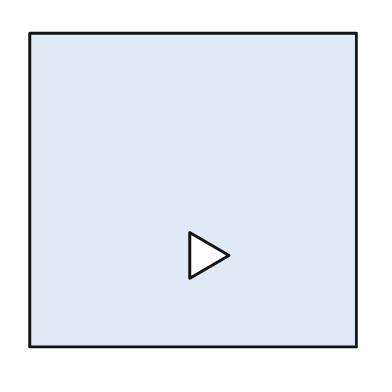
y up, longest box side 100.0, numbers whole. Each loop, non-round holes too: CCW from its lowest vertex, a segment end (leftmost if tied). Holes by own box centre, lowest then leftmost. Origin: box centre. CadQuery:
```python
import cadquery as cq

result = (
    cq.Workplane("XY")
    .moveTo(-50.0, -48.0)
    .lineTo(50.0, -48.0)
    .lineTo(50.0, 48.0)
    .lineTo(-50.0, 48.0)
    .close()
    .moveTo(-1.0, -27.0)
    .lineTo(11.0, -20.0)
    .lineTo(-1.0, -13.0)
    .close()
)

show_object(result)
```